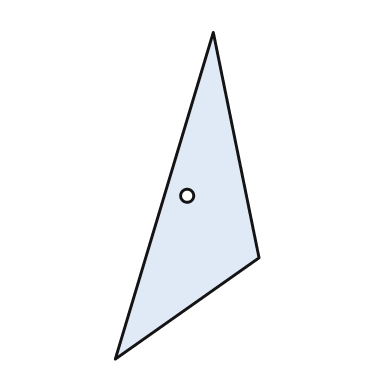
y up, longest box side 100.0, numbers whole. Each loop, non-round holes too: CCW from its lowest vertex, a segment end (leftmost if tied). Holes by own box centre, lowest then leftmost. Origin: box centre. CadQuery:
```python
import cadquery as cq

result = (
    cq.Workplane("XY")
    .moveTo(-22.0, -50.0)
    .lineTo(22.0, -19.0)
    .lineTo(8.0, 50.0)
    .close()
    .moveTo(0.0, 0.0)
    .circle(2.0)
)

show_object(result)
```